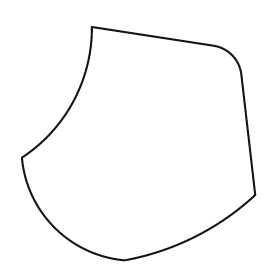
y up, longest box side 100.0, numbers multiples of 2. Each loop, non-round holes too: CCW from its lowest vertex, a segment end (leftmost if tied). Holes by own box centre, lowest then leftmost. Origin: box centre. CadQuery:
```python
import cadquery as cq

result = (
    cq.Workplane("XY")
    .moveTo(-6.0, -50.0)
    .threePointArc((24.0, -40.0), (50.0, -22.0))
    .lineTo(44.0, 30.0)
    .threePointArc((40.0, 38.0), (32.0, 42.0))
    .lineTo(-20.0, 50.0)
    .threePointArc((-28.0, 18.0), (-50.0, -6.0))
    .threePointArc((-36.0, -36.0), (-6.0, -50.0))
    .close()
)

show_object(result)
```